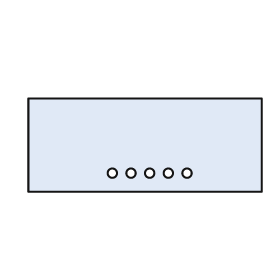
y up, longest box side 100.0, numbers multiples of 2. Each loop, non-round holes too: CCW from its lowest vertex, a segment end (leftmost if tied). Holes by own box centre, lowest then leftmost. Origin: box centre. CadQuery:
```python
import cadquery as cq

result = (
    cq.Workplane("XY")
    .moveTo(-50.0, -20.0)
    .lineTo(50.0, -20.0)
    .lineTo(50.0, 20.0)
    .lineTo(-50.0, 20.0)
    .close()
    .moveTo(-14.0, -12.0)
    .circle(2.0)
    .moveTo(-6.0, -12.0)
    .circle(2.0)
    .moveTo(2.0, -12.0)
    .circle(2.0)
    .moveTo(10.0, -12.0)
    .circle(2.0)
    .moveTo(18.0, -12.0)
    .circle(2.0)
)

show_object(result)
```